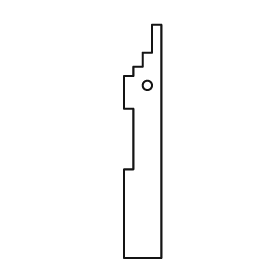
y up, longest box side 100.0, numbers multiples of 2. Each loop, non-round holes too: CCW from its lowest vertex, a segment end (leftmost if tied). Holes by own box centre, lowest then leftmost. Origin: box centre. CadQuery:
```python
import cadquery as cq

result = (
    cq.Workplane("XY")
    .moveTo(-8.0, -50.0)
    .lineTo(8.0, -50.0)
    .lineTo(8.0, 50.0)
    .lineTo(4.0, 50.0)
    .lineTo(4.0, 38.0)
    .lineTo(0.0, 38.0)
    .lineTo(0.0, 32.0)
    .lineTo(-4.0, 32.0)
    .lineTo(-4.0, 28.0)
    .lineTo(-8.0, 28.0)
    .lineTo(-8.0, 14.0)
    .lineTo(-4.0, 14.0)
    .lineTo(-4.0, -12.0)
    .lineTo(-8.0, -12.0)
    .close()
    .moveTo(2.0, 24.0)
    .circle(2.0)
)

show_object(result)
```